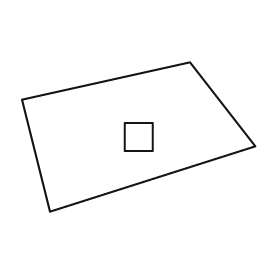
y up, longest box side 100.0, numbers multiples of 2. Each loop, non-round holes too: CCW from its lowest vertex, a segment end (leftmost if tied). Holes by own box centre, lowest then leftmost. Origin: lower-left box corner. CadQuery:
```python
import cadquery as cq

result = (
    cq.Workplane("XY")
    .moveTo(12.0, 0.0)
    .lineTo(100.0, 28.0)
    .lineTo(72.0, 64.0)
    .lineTo(0.0, 48.0)
    .close()
    .moveTo(44.0, 26.0)
    .lineTo(56.0, 26.0)
    .lineTo(56.0, 38.0)
    .lineTo(44.0, 38.0)
    .close()
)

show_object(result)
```